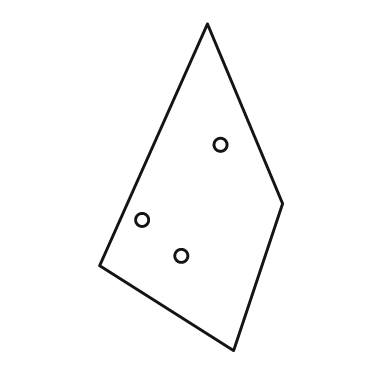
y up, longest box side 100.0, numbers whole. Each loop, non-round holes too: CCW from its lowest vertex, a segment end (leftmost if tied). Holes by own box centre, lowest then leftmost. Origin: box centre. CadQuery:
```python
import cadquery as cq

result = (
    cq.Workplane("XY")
    .moveTo(13.0, -50.0)
    .lineTo(28.0, -5.0)
    .lineTo(5.0, 50.0)
    .lineTo(-28.0, -24.0)
    .close()
    .moveTo(-3.0, -21.0)
    .circle(2.0)
    .moveTo(-15.0, -10.0)
    .circle(2.0)
    .moveTo(9.0, 13.0)
    .circle(2.0)
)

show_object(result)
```